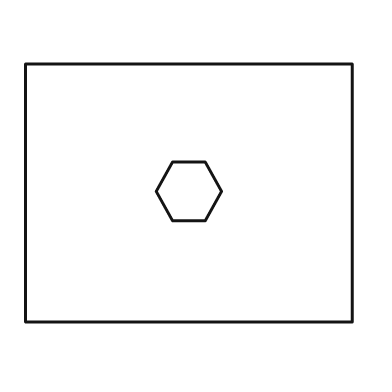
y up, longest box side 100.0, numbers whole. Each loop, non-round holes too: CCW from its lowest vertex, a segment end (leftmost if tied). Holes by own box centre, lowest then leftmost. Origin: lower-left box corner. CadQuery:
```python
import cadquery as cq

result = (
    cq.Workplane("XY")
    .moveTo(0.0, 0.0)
    .lineTo(100.0, 0.0)
    .lineTo(100.0, 79.0)
    .lineTo(0.0, 79.0)
    .close()
    .moveTo(45.0, 31.0)
    .lineTo(55.0, 31.0)
    .lineTo(60.0, 40.0)
    .lineTo(55.0, 49.0)
    .lineTo(45.0, 49.0)
    .lineTo(40.0, 40.0)
    .close()
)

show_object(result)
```